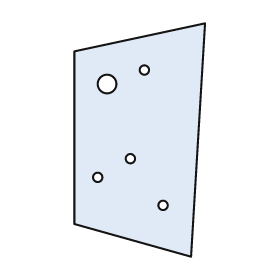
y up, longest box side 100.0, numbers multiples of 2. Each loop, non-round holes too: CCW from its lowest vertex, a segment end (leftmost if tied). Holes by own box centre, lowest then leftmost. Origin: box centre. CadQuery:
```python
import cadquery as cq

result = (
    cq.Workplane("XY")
    .moveTo(22.0, -50.0)
    .lineTo(28.0, 50.0)
    .lineTo(-28.0, 38.0)
    .lineTo(-28.0, -36.0)
    .close()
    .moveTo(10.0, -28.0)
    .circle(2.0)
    .moveTo(-18.0, -16.0)
    .circle(2.0)
    .moveTo(-4.0, -8.0)
    .circle(2.0)
    .moveTo(-14.0, 24.0)
    .circle(4.0)
    .moveTo(2.0, 30.0)
    .circle(2.0)
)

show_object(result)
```